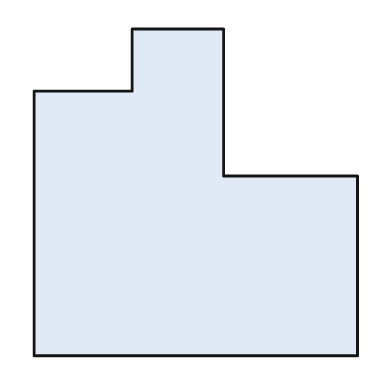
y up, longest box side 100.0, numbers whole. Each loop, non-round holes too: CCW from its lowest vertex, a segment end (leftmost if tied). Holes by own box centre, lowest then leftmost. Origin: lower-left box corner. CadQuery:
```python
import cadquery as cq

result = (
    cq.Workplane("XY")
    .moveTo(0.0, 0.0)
    .lineTo(99.0, 0.0)
    .lineTo(99.0, 55.0)
    .lineTo(58.0, 55.0)
    .lineTo(58.0, 100.0)
    .lineTo(30.0, 100.0)
    .lineTo(30.0, 81.0)
    .lineTo(0.0, 81.0)
    .close()
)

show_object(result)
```